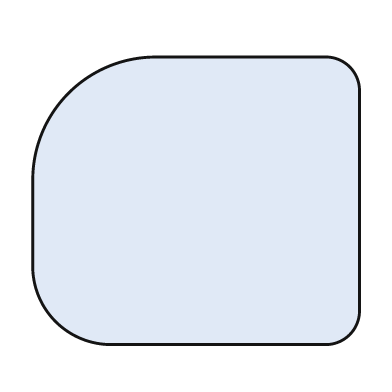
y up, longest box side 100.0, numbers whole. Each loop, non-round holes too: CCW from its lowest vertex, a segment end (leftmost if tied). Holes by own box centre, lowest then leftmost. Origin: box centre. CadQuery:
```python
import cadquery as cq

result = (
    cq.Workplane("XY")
    .moveTo(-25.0, -44.0)
    .lineTo(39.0, -44.0)
    .threePointArc((47.0, -41.0), (50.0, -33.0))
    .lineTo(50.0, 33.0)
    .threePointArc((47.0, 41.0), (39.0, 44.0))
    .lineTo(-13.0, 44.0)
    .threePointArc((-39.0, 33.0), (-50.0, 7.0))
    .lineTo(-50.0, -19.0)
    .threePointArc((-43.0, -37.0), (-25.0, -44.0))
    .close()
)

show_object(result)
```